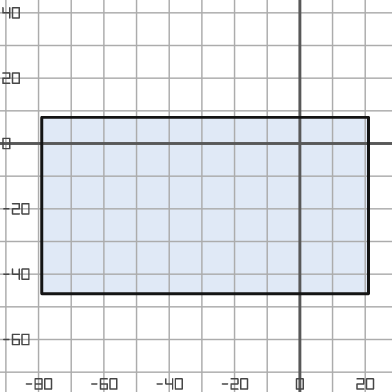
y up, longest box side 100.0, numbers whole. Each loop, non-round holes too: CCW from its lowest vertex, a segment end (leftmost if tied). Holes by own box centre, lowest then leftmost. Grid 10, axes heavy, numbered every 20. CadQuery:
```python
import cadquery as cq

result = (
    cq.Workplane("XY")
    .moveTo(-79.0, -46.0)
    .lineTo(21.0, -46.0)
    .lineTo(21.0, 8.0)
    .lineTo(-79.0, 8.0)
    .close()
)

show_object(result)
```